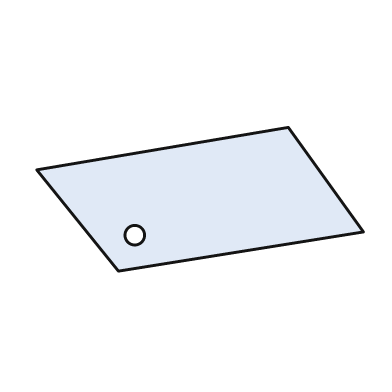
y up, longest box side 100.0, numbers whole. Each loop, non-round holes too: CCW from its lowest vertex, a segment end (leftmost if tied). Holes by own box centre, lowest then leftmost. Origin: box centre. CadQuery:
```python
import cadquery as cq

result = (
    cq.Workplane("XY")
    .moveTo(-25.0, -22.0)
    .lineTo(50.0, -10.0)
    .lineTo(27.0, 22.0)
    .lineTo(-50.0, 9.0)
    .close()
    .moveTo(-20.0, -11.0)
    .circle(3.0)
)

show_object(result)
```